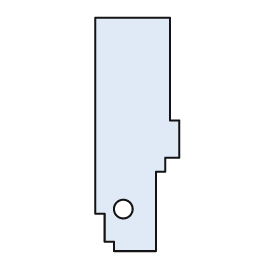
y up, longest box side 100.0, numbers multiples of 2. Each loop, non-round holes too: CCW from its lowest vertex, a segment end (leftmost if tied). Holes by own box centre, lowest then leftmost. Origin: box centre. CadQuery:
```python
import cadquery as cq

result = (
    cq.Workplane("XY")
    .moveTo(-10.0, -50.0)
    .lineTo(8.0, -50.0)
    .lineTo(8.0, -16.0)
    .lineTo(12.0, -16.0)
    .lineTo(12.0, -10.0)
    .lineTo(18.0, -10.0)
    .lineTo(18.0, 6.0)
    .lineTo(14.0, 6.0)
    .lineTo(14.0, 50.0)
    .lineTo(-18.0, 50.0)
    .lineTo(-18.0, -34.0)
    .lineTo(-14.0, -34.0)
    .lineTo(-14.0, -46.0)
    .lineTo(-10.0, -46.0)
    .close()
    .moveTo(-6.0, -32.0)
    .circle(4.0)
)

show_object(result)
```